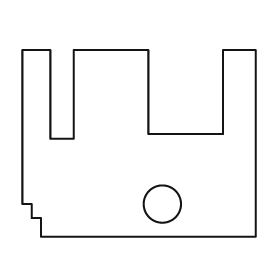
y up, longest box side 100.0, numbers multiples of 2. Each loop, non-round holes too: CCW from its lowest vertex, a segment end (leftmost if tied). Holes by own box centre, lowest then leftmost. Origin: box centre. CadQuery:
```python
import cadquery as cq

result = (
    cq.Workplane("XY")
    .moveTo(-42.0, -40.0)
    .lineTo(50.0, -40.0)
    .lineTo(50.0, 40.0)
    .lineTo(36.0, 40.0)
    .lineTo(36.0, 4.0)
    .lineTo(4.0, 4.0)
    .lineTo(4.0, 40.0)
    .lineTo(-28.0, 40.0)
    .lineTo(-28.0, 2.0)
    .lineTo(-38.0, 2.0)
    .lineTo(-38.0, 40.0)
    .lineTo(-50.0, 40.0)
    .lineTo(-50.0, -26.0)
    .lineTo(-46.0, -26.0)
    .lineTo(-46.0, -32.0)
    .lineTo(-42.0, -32.0)
    .close()
    .moveTo(10.0, -26.0)
    .circle(8.0)
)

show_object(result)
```